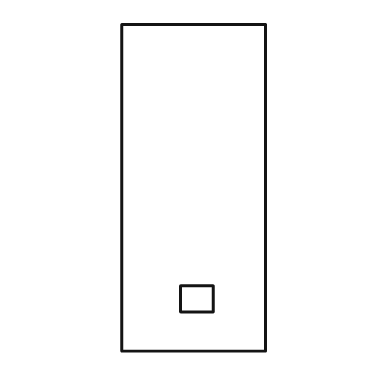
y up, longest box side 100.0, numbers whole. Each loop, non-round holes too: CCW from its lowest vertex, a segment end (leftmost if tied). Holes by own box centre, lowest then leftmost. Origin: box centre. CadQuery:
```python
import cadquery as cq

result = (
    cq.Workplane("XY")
    .moveTo(-22.0, -50.0)
    .lineTo(22.0, -50.0)
    .lineTo(22.0, 50.0)
    .lineTo(-22.0, 50.0)
    .close()
    .moveTo(-4.0, -38.0)
    .lineTo(6.0, -38.0)
    .lineTo(6.0, -30.0)
    .lineTo(-4.0, -30.0)
    .close()
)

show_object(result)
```